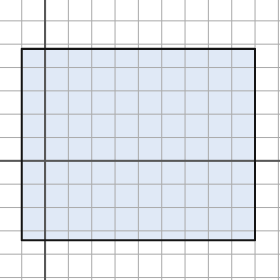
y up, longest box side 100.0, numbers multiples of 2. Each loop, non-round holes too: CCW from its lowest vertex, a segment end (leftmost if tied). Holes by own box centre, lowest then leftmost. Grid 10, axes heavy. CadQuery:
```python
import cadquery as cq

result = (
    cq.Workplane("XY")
    .moveTo(-10.0, -34.0)
    .lineTo(90.0, -34.0)
    .lineTo(90.0, 48.0)
    .lineTo(-10.0, 48.0)
    .close()
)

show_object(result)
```